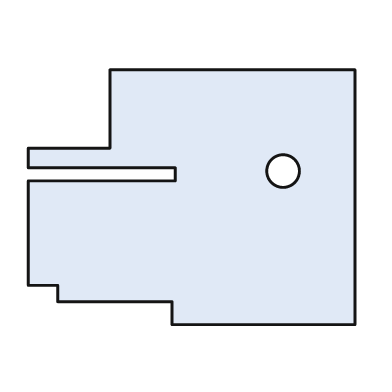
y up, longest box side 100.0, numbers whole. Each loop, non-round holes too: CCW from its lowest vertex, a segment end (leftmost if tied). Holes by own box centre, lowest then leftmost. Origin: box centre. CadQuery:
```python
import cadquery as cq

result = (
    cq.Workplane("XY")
    .moveTo(-6.0, -39.0)
    .lineTo(50.0, -39.0)
    .lineTo(50.0, 39.0)
    .lineTo(-25.0, 39.0)
    .lineTo(-25.0, 15.0)
    .lineTo(-50.0, 15.0)
    .lineTo(-50.0, 9.0)
    .lineTo(-5.0, 9.0)
    .lineTo(-5.0, 5.0)
    .lineTo(-50.0, 5.0)
    .lineTo(-50.0, -27.0)
    .lineTo(-41.0, -27.0)
    .lineTo(-41.0, -32.0)
    .lineTo(-6.0, -32.0)
    .close()
    .moveTo(28.0, 8.0)
    .circle(5.0)
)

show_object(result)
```